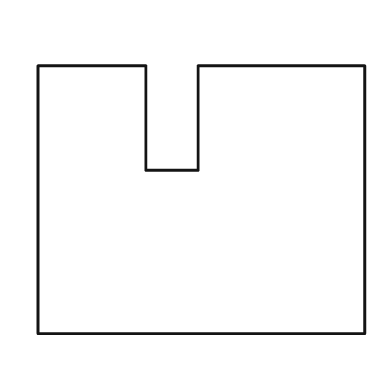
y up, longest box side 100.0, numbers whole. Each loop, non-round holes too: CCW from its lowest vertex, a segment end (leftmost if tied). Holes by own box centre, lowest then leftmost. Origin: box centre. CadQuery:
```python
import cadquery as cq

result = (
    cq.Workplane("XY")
    .moveTo(-50.0, -41.0)
    .lineTo(50.0, -41.0)
    .lineTo(50.0, 41.0)
    .lineTo(-1.0, 41.0)
    .lineTo(-1.0, 9.0)
    .lineTo(-17.0, 9.0)
    .lineTo(-17.0, 41.0)
    .lineTo(-50.0, 41.0)
    .close()
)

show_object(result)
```